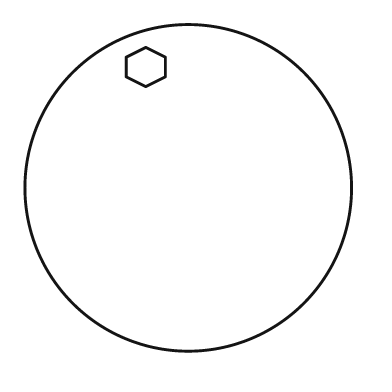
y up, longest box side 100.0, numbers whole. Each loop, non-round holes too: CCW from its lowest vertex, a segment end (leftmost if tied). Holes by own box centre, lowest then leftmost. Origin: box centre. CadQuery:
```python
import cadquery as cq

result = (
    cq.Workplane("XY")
    .moveTo(0.0, 0.0)
    .circle(50.0)
    .moveTo(-13.0, 31.0)
    .lineTo(-7.0, 34.0)
    .lineTo(-7.0, 40.0)
    .lineTo(-13.0, 43.0)
    .lineTo(-19.0, 40.0)
    .lineTo(-19.0, 34.0)
    .close()
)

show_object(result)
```